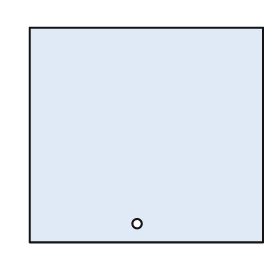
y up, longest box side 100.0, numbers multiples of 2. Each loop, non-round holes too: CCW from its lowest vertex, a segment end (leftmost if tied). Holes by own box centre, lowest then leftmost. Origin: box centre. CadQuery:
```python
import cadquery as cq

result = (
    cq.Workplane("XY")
    .moveTo(-50.0, -46.0)
    .lineTo(50.0, -46.0)
    .lineTo(50.0, 46.0)
    .lineTo(-50.0, 46.0)
    .close()
    .moveTo(-4.0, -38.0)
    .circle(2.0)
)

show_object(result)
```